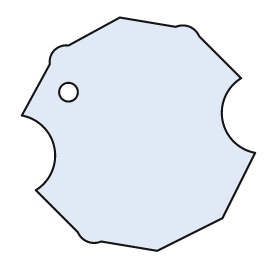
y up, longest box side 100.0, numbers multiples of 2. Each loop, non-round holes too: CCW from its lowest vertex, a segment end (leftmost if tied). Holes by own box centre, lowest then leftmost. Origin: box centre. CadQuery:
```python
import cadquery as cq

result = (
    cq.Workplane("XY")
    .moveTo(8.0, -50.0)
    .lineTo(36.0, -36.0)
    .lineTo(50.0, -8.0)
    .threePointArc((36.0, 6.0), (44.0, 24.0))
    .lineTo(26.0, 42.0)
    .threePointArc((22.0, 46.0), (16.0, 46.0))
    .lineTo(-8.0, 50.0)
    .lineTo(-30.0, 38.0)
    .threePointArc((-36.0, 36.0), (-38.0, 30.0))
    .lineTo(-50.0, 8.0)
    .threePointArc((-36.0, -6.0), (-44.0, -24.0))
    .lineTo(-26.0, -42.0)
    .threePointArc((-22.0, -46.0), (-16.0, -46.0))
    .close()
    .moveTo(-30.0, 18.0)
    .circle(4.0)
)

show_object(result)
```